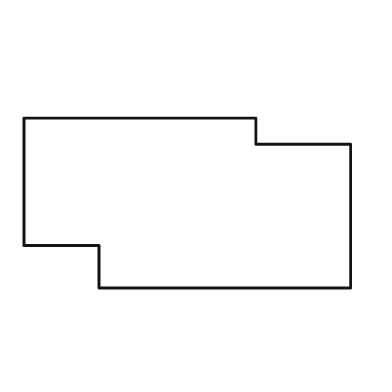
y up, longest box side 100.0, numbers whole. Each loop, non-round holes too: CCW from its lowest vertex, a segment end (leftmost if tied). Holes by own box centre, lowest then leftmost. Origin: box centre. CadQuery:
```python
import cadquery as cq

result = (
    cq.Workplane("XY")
    .moveTo(-27.0, -26.0)
    .lineTo(50.0, -26.0)
    .lineTo(50.0, 18.0)
    .lineTo(21.0, 18.0)
    .lineTo(21.0, 26.0)
    .lineTo(-50.0, 26.0)
    .lineTo(-50.0, -13.0)
    .lineTo(-27.0, -13.0)
    .close()
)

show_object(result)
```